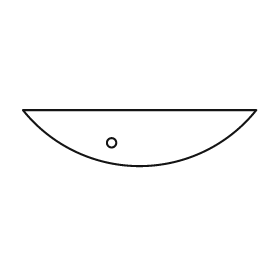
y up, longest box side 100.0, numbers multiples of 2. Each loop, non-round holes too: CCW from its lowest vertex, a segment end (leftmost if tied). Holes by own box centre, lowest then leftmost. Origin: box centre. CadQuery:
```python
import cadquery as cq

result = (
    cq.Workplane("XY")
    .moveTo(-50.0, 12.0)
    .threePointArc((0.0, -12.0), (50.0, 12.0))
    .close()
    .moveTo(-12.0, -2.0)
    .circle(2.0)
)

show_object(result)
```